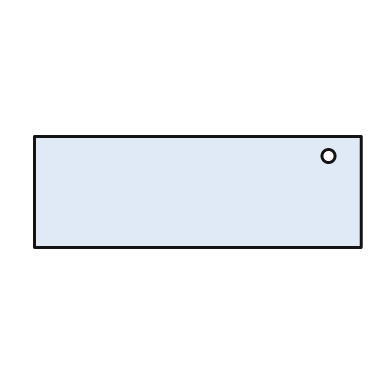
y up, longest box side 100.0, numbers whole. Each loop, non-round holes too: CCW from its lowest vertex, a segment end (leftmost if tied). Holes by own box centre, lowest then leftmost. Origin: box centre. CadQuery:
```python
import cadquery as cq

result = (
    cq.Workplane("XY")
    .moveTo(-50.0, -17.0)
    .lineTo(50.0, -17.0)
    .lineTo(50.0, 17.0)
    .lineTo(-50.0, 17.0)
    .close()
    .moveTo(40.0, 11.0)
    .circle(2.0)
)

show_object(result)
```